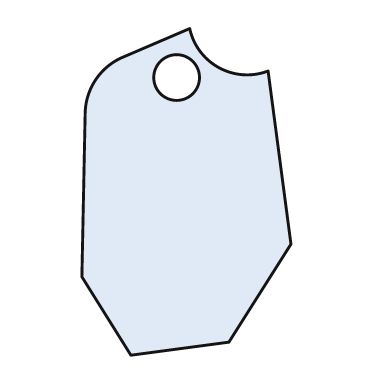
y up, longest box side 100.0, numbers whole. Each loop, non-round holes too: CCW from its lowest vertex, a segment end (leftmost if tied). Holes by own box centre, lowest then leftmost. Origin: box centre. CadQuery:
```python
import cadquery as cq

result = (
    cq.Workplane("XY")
    .moveTo(-17.0, -50.0)
    .lineTo(13.0, -46.0)
    .lineTo(32.0, -16.0)
    .lineTo(25.0, 37.0)
    .threePointArc((10.0, 38.0), (1.0, 50.0))
    .lineTo(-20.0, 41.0)
    .threePointArc((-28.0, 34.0), (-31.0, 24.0))
    .lineTo(-32.0, -26.0)
    .close()
    .moveTo(-3.0, 35.0)
    .circle(7.0)
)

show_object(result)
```